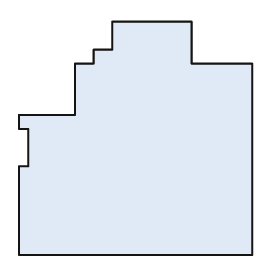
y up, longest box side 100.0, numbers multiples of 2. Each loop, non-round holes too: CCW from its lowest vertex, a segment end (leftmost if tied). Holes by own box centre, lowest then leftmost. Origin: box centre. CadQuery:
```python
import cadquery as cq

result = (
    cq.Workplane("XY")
    .moveTo(-50.0, -50.0)
    .lineTo(50.0, -50.0)
    .lineTo(50.0, 32.0)
    .lineTo(24.0, 32.0)
    .lineTo(24.0, 50.0)
    .lineTo(-10.0, 50.0)
    .lineTo(-10.0, 38.0)
    .lineTo(-18.0, 38.0)
    .lineTo(-18.0, 32.0)
    .lineTo(-26.0, 32.0)
    .lineTo(-26.0, 10.0)
    .lineTo(-50.0, 10.0)
    .lineTo(-50.0, 4.0)
    .lineTo(-46.0, 4.0)
    .lineTo(-46.0, -12.0)
    .lineTo(-50.0, -12.0)
    .close()
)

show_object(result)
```